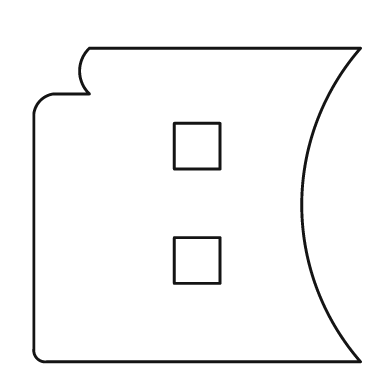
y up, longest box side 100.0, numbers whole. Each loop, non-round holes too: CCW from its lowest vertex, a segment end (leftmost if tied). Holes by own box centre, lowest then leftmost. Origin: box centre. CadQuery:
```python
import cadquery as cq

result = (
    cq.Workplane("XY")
    .moveTo(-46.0, -48.0)
    .lineTo(50.0, -48.0)
    .threePointArc((32.0, 0.0), (50.0, 48.0))
    .lineTo(-33.0, 48.0)
    .threePointArc((-36.0, 41.0), (-33.0, 34.0))
    .lineTo(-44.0, 34.0)
    .threePointArc((-48.0, 32.0), (-50.0, 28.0))
    .lineTo(-50.0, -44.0)
    .threePointArc((-49.0, -47.0), (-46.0, -48.0))
    .close()
    .moveTo(-7.0, -24.0)
    .lineTo(7.0, -24.0)
    .lineTo(7.0, -10.0)
    .lineTo(-7.0, -10.0)
    .close()
    .moveTo(-7.0, 11.0)
    .lineTo(7.0, 11.0)
    .lineTo(7.0, 25.0)
    .lineTo(-7.0, 25.0)
    .close()
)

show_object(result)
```